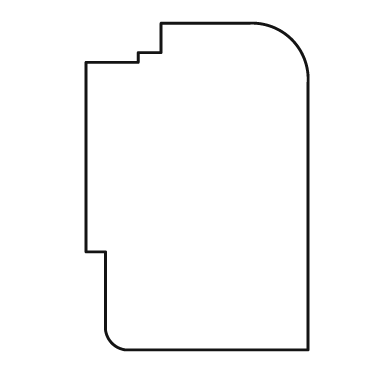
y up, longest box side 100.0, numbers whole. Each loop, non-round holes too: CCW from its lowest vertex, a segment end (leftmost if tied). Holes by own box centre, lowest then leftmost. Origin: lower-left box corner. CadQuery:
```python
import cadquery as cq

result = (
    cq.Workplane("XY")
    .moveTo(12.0, 0.0)
    .lineTo(68.0, 0.0)
    .lineTo(68.0, 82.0)
    .threePointArc((63.0, 95.0), (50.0, 100.0))
    .lineTo(23.0, 100.0)
    .lineTo(23.0, 91.0)
    .lineTo(16.0, 91.0)
    .lineTo(16.0, 88.0)
    .lineTo(0.0, 88.0)
    .lineTo(0.0, 30.0)
    .lineTo(6.0, 30.0)
    .lineTo(6.0, 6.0)
    .threePointArc((8.0, 2.0), (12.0, 0.0))
    .close()
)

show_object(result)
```